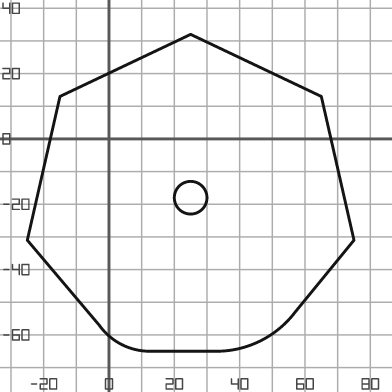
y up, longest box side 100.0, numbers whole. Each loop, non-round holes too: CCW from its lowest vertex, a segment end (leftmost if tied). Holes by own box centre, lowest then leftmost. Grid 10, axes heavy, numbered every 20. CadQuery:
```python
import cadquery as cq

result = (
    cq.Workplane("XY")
    .moveTo(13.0, -65.0)
    .lineTo(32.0, -65.0)
    .threePointArc((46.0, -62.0), (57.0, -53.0))
    .lineTo(75.0, -31.0)
    .lineTo(65.0, 13.0)
    .lineTo(25.0, 32.0)
    .lineTo(-15.0, 13.0)
    .lineTo(-25.0, -31.0)
    .lineTo(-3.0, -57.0)
    .threePointArc((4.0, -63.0), (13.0, -65.0))
    .close()
    .moveTo(25.0, -18.0)
    .circle(5.0)
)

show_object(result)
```